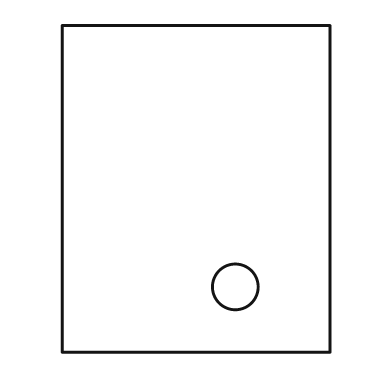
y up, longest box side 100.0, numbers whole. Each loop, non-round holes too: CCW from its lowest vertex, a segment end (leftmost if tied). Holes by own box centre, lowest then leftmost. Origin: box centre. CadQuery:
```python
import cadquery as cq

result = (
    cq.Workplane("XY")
    .moveTo(-41.0, -50.0)
    .lineTo(41.0, -50.0)
    .lineTo(41.0, 50.0)
    .lineTo(-41.0, 50.0)
    .close()
    .moveTo(12.0, -30.0)
    .circle(7.0)
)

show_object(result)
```